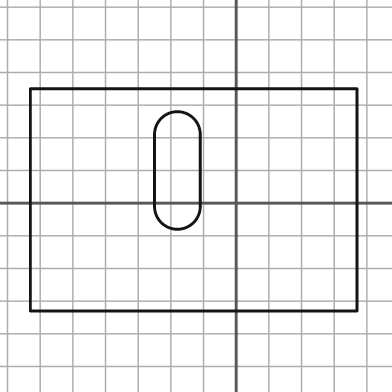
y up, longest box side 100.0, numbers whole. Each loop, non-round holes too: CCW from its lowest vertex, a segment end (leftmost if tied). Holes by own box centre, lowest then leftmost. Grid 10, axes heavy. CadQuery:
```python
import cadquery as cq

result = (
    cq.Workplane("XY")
    .moveTo(-63.0, -33.0)
    .lineTo(37.0, -33.0)
    .lineTo(37.0, 35.0)
    .lineTo(-63.0, 35.0)
    .close()
    .moveTo(-25.0, -1.0)
    .threePointArc((-18.0, -8.0), (-11.0, -1.0))
    .lineTo(-11.0, 21.0)
    .threePointArc((-18.0, 28.0), (-25.0, 21.0))
    .close()
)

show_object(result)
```